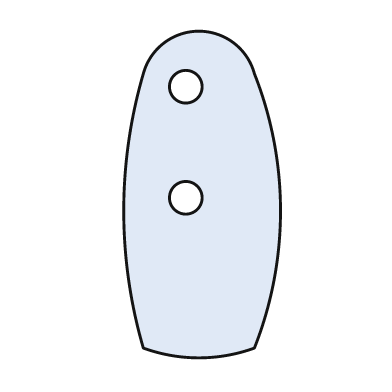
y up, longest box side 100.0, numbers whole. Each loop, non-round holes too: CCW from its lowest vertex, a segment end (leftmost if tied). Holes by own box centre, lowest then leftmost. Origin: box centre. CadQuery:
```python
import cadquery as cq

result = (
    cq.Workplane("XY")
    .moveTo(-18.0, -47.0)
    .threePointArc((-1.0, -50.0), (16.0, -47.0))
    .threePointArc((24.0, -5.0), (16.0, 37.0))
    .threePointArc((-1.0, 50.0), (-18.0, 37.0))
    .threePointArc((-24.0, -5.0), (-18.0, -47.0))
    .close()
    .moveTo(-5.0, -1.0)
    .circle(5.0)
    .moveTo(-5.0, 33.0)
    .circle(5.0)
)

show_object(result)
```